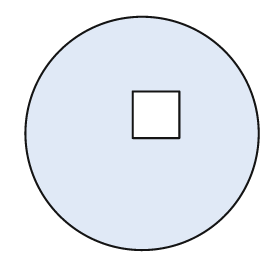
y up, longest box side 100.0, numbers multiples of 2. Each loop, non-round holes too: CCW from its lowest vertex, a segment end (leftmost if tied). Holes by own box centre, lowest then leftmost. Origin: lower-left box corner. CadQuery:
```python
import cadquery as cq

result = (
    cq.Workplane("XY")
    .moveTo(50.0, 50.0)
    .circle(50.0)
    .moveTo(46.0, 48.0)
    .lineTo(66.0, 48.0)
    .lineTo(66.0, 68.0)
    .lineTo(46.0, 68.0)
    .close()
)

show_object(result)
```